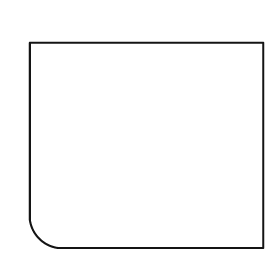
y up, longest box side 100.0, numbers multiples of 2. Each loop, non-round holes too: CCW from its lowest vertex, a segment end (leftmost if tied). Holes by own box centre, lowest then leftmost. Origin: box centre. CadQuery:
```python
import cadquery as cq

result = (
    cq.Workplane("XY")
    .moveTo(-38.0, -44.0)
    .lineTo(50.0, -44.0)
    .lineTo(50.0, 44.0)
    .lineTo(-50.0, 44.0)
    .lineTo(-50.0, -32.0)
    .threePointArc((-46.0, -40.0), (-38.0, -44.0))
    .close()
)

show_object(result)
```